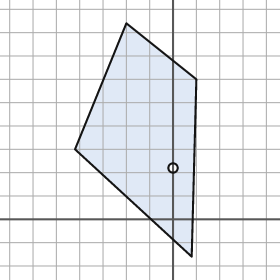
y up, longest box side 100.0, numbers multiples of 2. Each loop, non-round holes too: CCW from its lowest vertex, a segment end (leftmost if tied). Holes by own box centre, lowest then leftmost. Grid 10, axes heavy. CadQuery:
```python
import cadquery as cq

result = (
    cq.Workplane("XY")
    .moveTo(8.0, -16.0)
    .lineTo(10.0, 60.0)
    .lineTo(-20.0, 84.0)
    .lineTo(-42.0, 30.0)
    .close()
    .moveTo(0.0, 22.0)
    .circle(2.0)
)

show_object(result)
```